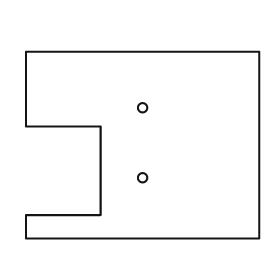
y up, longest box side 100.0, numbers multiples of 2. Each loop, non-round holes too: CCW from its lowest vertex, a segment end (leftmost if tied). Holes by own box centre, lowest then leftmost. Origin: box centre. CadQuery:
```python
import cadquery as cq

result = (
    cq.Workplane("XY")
    .moveTo(-50.0, -40.0)
    .lineTo(50.0, -40.0)
    .lineTo(50.0, 40.0)
    .lineTo(-50.0, 40.0)
    .lineTo(-50.0, 8.0)
    .lineTo(-18.0, 8.0)
    .lineTo(-18.0, -30.0)
    .lineTo(-50.0, -30.0)
    .close()
    .moveTo(0.0, -14.0)
    .circle(2.0)
    .moveTo(0.0, 16.0)
    .circle(2.0)
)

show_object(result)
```